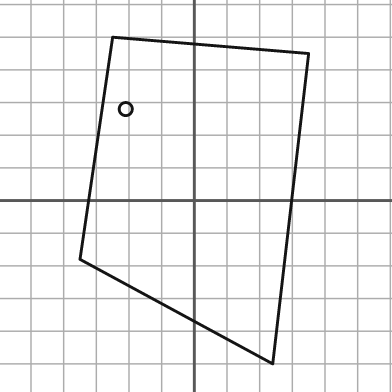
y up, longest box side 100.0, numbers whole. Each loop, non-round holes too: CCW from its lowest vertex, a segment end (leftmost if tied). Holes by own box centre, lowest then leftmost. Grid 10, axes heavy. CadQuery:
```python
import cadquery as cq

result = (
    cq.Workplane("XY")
    .moveTo(24.0, -50.0)
    .lineTo(35.0, 45.0)
    .lineTo(-25.0, 50.0)
    .lineTo(-35.0, -18.0)
    .close()
    .moveTo(-21.0, 28.0)
    .circle(2.0)
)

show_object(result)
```